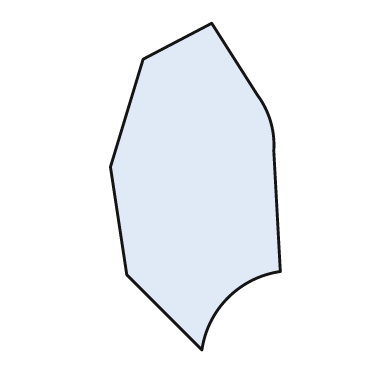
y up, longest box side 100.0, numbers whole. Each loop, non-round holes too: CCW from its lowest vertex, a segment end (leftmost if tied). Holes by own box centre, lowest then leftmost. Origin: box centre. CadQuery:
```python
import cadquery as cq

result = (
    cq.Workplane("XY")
    .moveTo(2.0, -50.0)
    .threePointArc((10.0, -34.0), (26.0, -26.0))
    .lineTo(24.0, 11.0)
    .threePointArc((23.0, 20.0), (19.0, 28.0))
    .lineTo(5.0, 50.0)
    .lineTo(-16.0, 39.0)
    .lineTo(-26.0, 6.0)
    .lineTo(-21.0, -27.0)
    .close()
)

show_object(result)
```